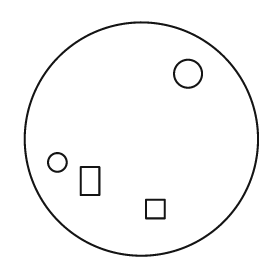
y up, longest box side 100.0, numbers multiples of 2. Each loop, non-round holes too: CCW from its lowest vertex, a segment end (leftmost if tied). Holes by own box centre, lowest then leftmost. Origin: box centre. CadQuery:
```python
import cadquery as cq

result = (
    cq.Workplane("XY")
    .moveTo(0.0, 0.0)
    .circle(50.0)
    .moveTo(2.0, -34.0)
    .lineTo(10.0, -34.0)
    .lineTo(10.0, -26.0)
    .lineTo(2.0, -26.0)
    .close()
    .moveTo(-26.0, -24.0)
    .lineTo(-18.0, -24.0)
    .lineTo(-18.0, -12.0)
    .lineTo(-26.0, -12.0)
    .close()
    .moveTo(-36.0, -10.0)
    .circle(4.0)
    .moveTo(20.0, 28.0)
    .circle(6.0)
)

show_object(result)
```